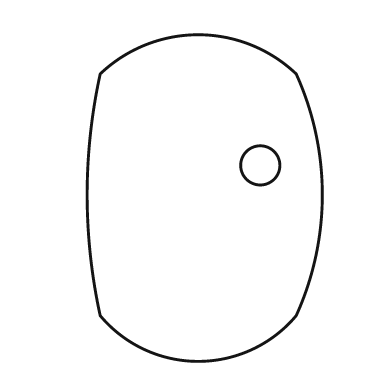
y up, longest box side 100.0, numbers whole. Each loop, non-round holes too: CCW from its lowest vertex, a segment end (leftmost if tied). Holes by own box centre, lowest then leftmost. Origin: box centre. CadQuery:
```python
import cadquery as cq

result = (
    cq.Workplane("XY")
    .moveTo(-32.0, -36.0)
    .threePointArc((-2.0, -50.0), (28.0, -36.0))
    .threePointArc((36.0, 1.0), (28.0, 38.0))
    .threePointArc((-2.0, 50.0), (-32.0, 38.0))
    .threePointArc((-36.0, 1.0), (-32.0, -36.0))
    .close()
    .moveTo(17.0, 10.0)
    .circle(6.0)
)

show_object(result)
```